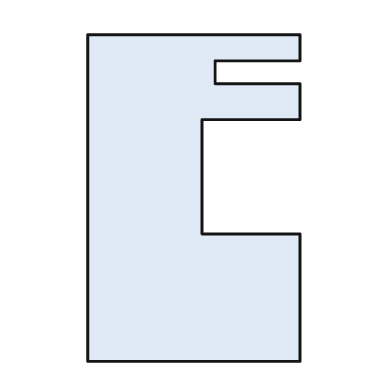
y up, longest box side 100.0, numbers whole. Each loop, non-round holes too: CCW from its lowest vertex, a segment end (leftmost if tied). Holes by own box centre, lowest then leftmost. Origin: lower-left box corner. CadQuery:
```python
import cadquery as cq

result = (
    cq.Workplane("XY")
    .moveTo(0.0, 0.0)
    .lineTo(65.0, 0.0)
    .lineTo(65.0, 39.0)
    .lineTo(35.0, 39.0)
    .lineTo(35.0, 74.0)
    .lineTo(65.0, 74.0)
    .lineTo(65.0, 85.0)
    .lineTo(39.0, 85.0)
    .lineTo(39.0, 92.0)
    .lineTo(65.0, 92.0)
    .lineTo(65.0, 100.0)
    .lineTo(0.0, 100.0)
    .close()
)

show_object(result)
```